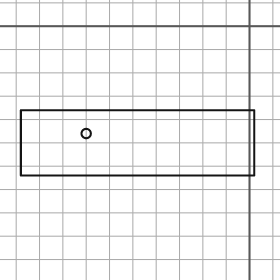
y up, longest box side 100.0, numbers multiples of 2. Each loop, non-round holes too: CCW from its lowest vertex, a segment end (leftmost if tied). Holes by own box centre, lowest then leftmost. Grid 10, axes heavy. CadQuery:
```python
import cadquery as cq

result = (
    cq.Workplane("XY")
    .moveTo(-98.0, -64.0)
    .lineTo(2.0, -64.0)
    .lineTo(2.0, -36.0)
    .lineTo(-98.0, -36.0)
    .close()
    .moveTo(-70.0, -46.0)
    .circle(2.0)
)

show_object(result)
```